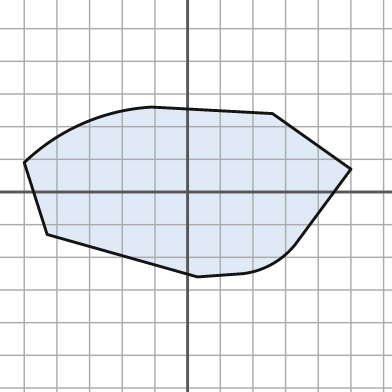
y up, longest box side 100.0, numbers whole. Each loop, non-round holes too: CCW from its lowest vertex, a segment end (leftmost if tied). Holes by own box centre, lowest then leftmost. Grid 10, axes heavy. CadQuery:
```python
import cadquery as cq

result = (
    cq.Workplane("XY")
    .moveTo(3.0, -26.0)
    .lineTo(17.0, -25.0)
    .threePointArc((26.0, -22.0), (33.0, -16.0))
    .lineTo(50.0, 7.0)
    .lineTo(26.0, 24.0)
    .lineTo(-11.0, 26.0)
    .threePointArc((-32.0, 21.0), (-50.0, 9.0))
    .lineTo(-43.0, -13.0)
    .close()
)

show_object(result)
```